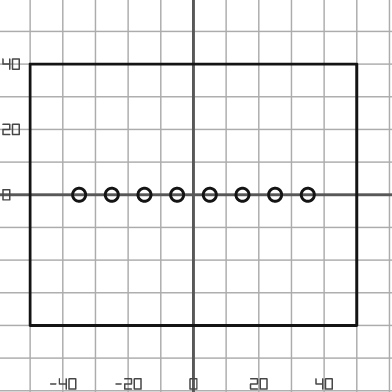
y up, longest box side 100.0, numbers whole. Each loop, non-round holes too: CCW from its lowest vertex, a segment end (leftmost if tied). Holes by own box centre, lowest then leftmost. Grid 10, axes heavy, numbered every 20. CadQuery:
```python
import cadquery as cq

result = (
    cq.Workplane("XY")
    .moveTo(-50.0, -40.0)
    .lineTo(50.0, -40.0)
    .lineTo(50.0, 40.0)
    .lineTo(-50.0, 40.0)
    .close()
    .moveTo(-35.0, 0.0)
    .circle(2.0)
    .moveTo(-25.0, 0.0)
    .circle(2.0)
    .moveTo(-15.0, 0.0)
    .circle(2.0)
    .moveTo(-5.0, 0.0)
    .circle(2.0)
    .moveTo(5.0, 0.0)
    .circle(2.0)
    .moveTo(15.0, 0.0)
    .circle(2.0)
    .moveTo(25.0, 0.0)
    .circle(2.0)
    .moveTo(35.0, 0.0)
    .circle(2.0)
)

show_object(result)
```